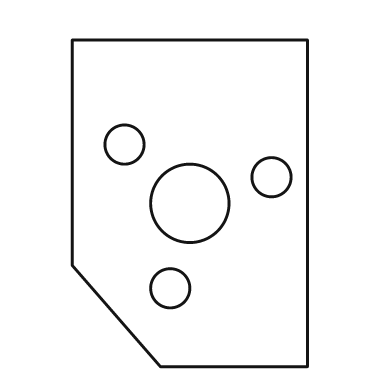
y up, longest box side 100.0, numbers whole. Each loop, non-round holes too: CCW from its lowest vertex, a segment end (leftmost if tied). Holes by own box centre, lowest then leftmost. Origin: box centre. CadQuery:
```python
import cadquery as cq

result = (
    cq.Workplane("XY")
    .moveTo(-9.0, -50.0)
    .lineTo(36.0, -50.0)
    .lineTo(36.0, 50.0)
    .lineTo(-36.0, 50.0)
    .lineTo(-36.0, -19.0)
    .close()
    .moveTo(-6.0, -26.0)
    .circle(6.0)
    .moveTo(0.0, 0.0)
    .circle(12.0)
    .moveTo(25.0, 8.0)
    .circle(6.0)
    .moveTo(-20.0, 18.0)
    .circle(6.0)
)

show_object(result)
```